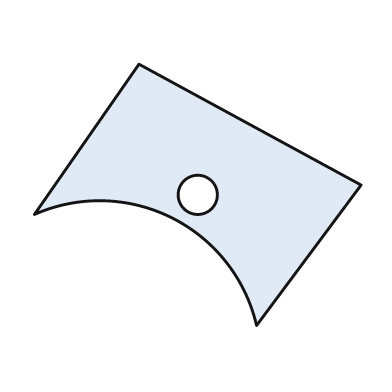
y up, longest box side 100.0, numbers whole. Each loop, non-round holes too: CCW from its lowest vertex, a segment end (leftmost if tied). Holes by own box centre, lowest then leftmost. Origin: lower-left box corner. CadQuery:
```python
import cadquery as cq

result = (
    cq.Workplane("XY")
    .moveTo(68.0, 0.0)
    .lineTo(100.0, 43.0)
    .lineTo(32.0, 80.0)
    .lineTo(0.0, 34.0)
    .threePointArc((42.0, 33.0), (68.0, 0.0))
    .close()
    .moveTo(50.0, 40.0)
    .circle(6.0)
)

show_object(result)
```